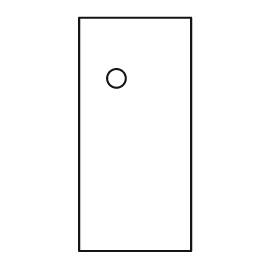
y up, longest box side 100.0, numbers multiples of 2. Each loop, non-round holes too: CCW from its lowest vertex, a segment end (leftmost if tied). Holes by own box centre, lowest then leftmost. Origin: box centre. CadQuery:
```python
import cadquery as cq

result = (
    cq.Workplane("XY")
    .moveTo(-24.0, -50.0)
    .lineTo(24.0, -50.0)
    .lineTo(24.0, 50.0)
    .lineTo(-24.0, 50.0)
    .close()
    .moveTo(-8.0, 24.0)
    .circle(4.0)
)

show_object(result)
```